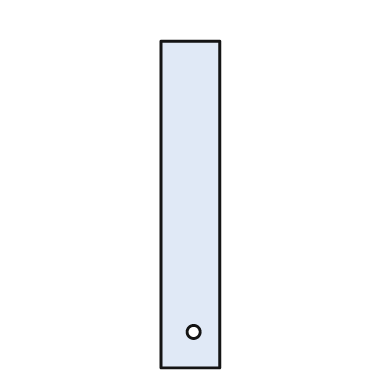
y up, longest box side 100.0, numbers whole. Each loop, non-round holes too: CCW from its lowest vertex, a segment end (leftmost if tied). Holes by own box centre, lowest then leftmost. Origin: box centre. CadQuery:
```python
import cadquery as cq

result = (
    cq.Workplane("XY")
    .moveTo(-9.0, -50.0)
    .lineTo(9.0, -50.0)
    .lineTo(9.0, 50.0)
    .lineTo(-9.0, 50.0)
    .close()
    .moveTo(1.0, -39.0)
    .circle(2.0)
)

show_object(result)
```